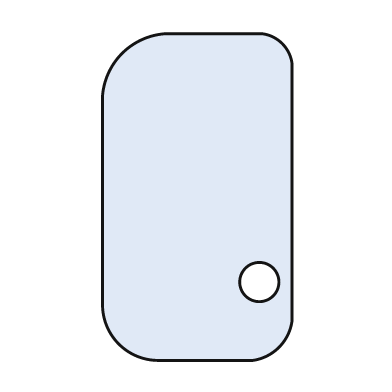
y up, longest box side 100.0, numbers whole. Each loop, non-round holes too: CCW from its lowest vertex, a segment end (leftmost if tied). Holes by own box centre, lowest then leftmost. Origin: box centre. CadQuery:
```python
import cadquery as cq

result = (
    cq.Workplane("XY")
    .moveTo(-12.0, -50.0)
    .lineTo(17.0, -50.0)
    .threePointArc((25.0, -46.0), (29.0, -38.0))
    .lineTo(29.0, 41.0)
    .threePointArc((26.0, 47.0), (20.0, 50.0))
    .lineTo(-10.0, 50.0)
    .threePointArc((-23.0, 44.0), (-29.0, 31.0))
    .lineTo(-29.0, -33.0)
    .threePointArc((-24.0, -45.0), (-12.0, -50.0))
    .close()
    .moveTo(19.0, -26.0)
    .circle(6.0)
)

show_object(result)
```